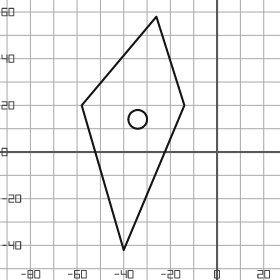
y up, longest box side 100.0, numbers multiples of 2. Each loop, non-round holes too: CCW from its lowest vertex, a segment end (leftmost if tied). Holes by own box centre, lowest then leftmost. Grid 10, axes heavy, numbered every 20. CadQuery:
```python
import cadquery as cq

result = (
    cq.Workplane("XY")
    .moveTo(-40.0, -42.0)
    .lineTo(-14.0, 20.0)
    .lineTo(-26.0, 58.0)
    .lineTo(-58.0, 20.0)
    .close()
    .moveTo(-34.0, 14.0)
    .circle(4.0)
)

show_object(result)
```